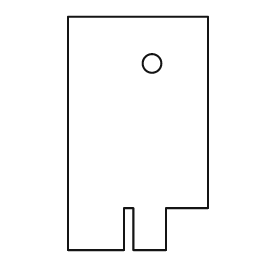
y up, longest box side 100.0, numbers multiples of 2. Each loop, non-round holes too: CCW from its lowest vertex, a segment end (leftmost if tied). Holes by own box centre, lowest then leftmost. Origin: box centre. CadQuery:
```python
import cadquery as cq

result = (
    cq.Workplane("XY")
    .moveTo(-30.0, -50.0)
    .lineTo(-6.0, -50.0)
    .lineTo(-6.0, -32.0)
    .lineTo(-2.0, -32.0)
    .lineTo(-2.0, -50.0)
    .lineTo(12.0, -50.0)
    .lineTo(12.0, -32.0)
    .lineTo(30.0, -32.0)
    .lineTo(30.0, 50.0)
    .lineTo(-30.0, 50.0)
    .close()
    .moveTo(6.0, 30.0)
    .circle(4.0)
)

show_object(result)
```